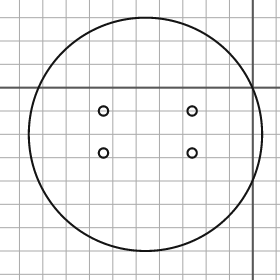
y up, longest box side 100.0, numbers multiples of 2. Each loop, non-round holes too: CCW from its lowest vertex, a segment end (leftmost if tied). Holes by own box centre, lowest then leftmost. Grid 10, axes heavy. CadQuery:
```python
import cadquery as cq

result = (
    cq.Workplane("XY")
    .moveTo(-46.0, -20.0)
    .circle(50.0)
    .moveTo(-64.0, -28.0)
    .circle(2.0)
    .moveTo(-26.0, -28.0)
    .circle(2.0)
    .moveTo(-64.0, -10.0)
    .circle(2.0)
    .moveTo(-26.0, -10.0)
    .circle(2.0)
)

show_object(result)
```